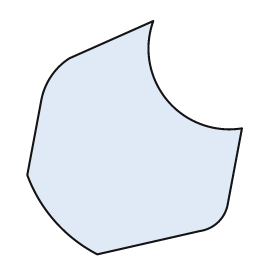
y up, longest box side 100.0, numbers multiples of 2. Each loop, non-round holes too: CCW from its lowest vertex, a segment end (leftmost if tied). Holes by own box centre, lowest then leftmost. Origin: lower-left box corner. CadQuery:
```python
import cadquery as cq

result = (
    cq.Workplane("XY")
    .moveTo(30.0, 0.0)
    .lineTo(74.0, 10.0)
    .threePointArc((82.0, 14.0), (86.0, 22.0))
    .lineTo(92.0, 54.0)
    .threePointArc((60.0, 66.0), (54.0, 100.0))
    .lineTo(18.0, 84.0)
    .threePointArc((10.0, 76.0), (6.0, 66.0))
    .lineTo(0.0, 34.0)
    .threePointArc((12.0, 14.0), (30.0, 0.0))
    .close()
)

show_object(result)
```